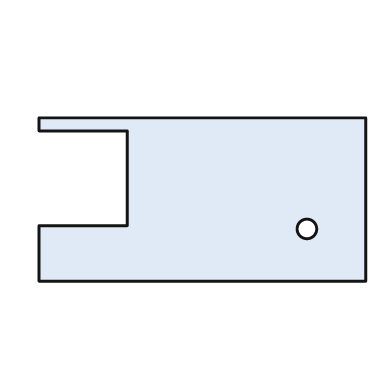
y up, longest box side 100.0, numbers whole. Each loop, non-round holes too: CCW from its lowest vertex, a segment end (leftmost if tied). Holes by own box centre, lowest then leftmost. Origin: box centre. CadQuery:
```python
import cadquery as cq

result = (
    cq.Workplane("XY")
    .moveTo(-50.0, -25.0)
    .lineTo(50.0, -25.0)
    .lineTo(50.0, 25.0)
    .lineTo(-50.0, 25.0)
    .lineTo(-50.0, 21.0)
    .lineTo(-23.0, 21.0)
    .lineTo(-23.0, -8.0)
    .lineTo(-50.0, -8.0)
    .close()
    .moveTo(32.0, -9.0)
    .circle(3.0)
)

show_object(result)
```